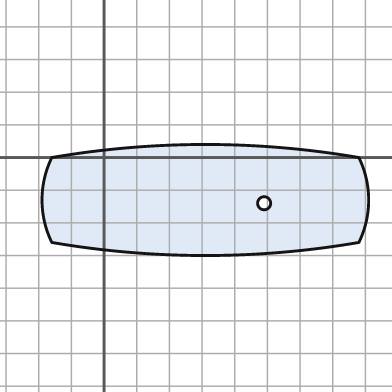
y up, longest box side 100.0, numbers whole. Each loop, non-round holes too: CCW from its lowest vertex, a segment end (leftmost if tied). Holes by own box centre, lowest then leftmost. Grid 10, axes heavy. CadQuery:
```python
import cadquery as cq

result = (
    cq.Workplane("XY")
    .moveTo(-16.0, -26.0)
    .threePointArc((31.0, -30.0), (78.0, -26.0))
    .threePointArc((81.0, -13.0), (78.0, 0.0))
    .threePointArc((31.0, 4.0), (-16.0, 0.0))
    .threePointArc((-19.0, -13.0), (-16.0, -26.0))
    .close()
    .moveTo(49.0, -14.0)
    .circle(2.0)
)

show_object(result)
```